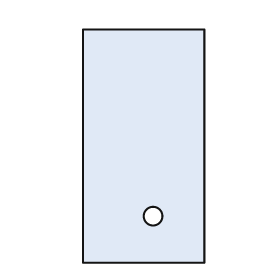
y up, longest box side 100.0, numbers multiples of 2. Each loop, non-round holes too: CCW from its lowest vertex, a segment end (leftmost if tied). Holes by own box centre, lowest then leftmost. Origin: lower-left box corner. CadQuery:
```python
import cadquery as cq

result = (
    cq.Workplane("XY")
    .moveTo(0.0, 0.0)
    .lineTo(52.0, 0.0)
    .lineTo(52.0, 100.0)
    .lineTo(0.0, 100.0)
    .close()
    .moveTo(30.0, 20.0)
    .circle(4.0)
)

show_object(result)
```